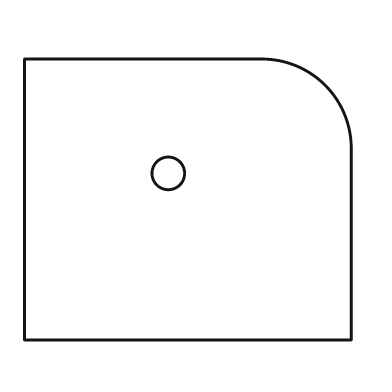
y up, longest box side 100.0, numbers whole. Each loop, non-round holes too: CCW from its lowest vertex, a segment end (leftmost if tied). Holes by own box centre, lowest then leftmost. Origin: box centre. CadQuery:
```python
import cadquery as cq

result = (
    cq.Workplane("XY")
    .moveTo(-50.0, -43.0)
    .lineTo(50.0, -43.0)
    .lineTo(50.0, 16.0)
    .threePointArc((42.0, 35.0), (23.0, 43.0))
    .lineTo(-50.0, 43.0)
    .close()
    .moveTo(-6.0, 8.0)
    .circle(5.0)
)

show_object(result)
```